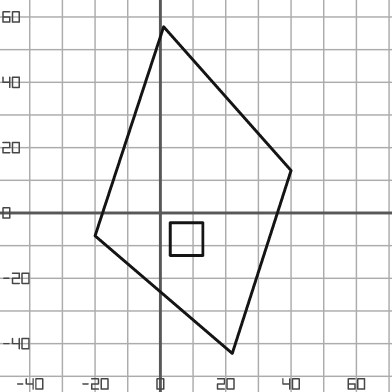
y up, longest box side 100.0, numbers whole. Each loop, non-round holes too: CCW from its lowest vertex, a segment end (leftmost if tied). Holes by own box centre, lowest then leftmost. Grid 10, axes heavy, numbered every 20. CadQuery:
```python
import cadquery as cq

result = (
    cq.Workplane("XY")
    .moveTo(22.0, -43.0)
    .lineTo(40.0, 13.0)
    .lineTo(1.0, 57.0)
    .lineTo(-20.0, -7.0)
    .close()
    .moveTo(3.0, -13.0)
    .lineTo(13.0, -13.0)
    .lineTo(13.0, -3.0)
    .lineTo(3.0, -3.0)
    .close()
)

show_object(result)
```